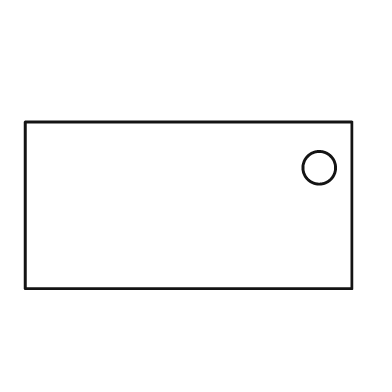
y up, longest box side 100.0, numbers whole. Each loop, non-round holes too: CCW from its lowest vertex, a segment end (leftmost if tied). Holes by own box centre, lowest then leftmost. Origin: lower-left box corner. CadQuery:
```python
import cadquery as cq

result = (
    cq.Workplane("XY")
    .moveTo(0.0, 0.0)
    .lineTo(100.0, 0.0)
    .lineTo(100.0, 51.0)
    .lineTo(0.0, 51.0)
    .close()
    .moveTo(90.0, 37.0)
    .circle(5.0)
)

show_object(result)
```